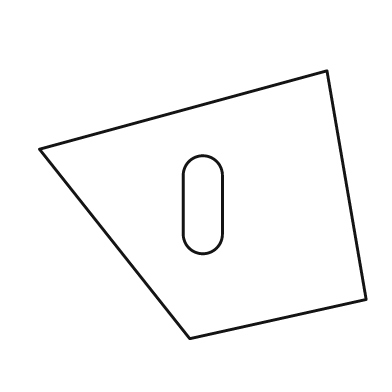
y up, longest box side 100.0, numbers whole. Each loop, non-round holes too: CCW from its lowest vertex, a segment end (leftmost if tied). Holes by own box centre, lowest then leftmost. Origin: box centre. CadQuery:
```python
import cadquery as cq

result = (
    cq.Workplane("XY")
    .moveTo(-4.0, -41.0)
    .lineTo(50.0, -29.0)
    .lineTo(38.0, 41.0)
    .lineTo(-50.0, 17.0)
    .close()
    .moveTo(-6.0, -9.0)
    .threePointArc((0.0, -15.0), (6.0, -9.0))
    .lineTo(6.0, 9.0)
    .threePointArc((0.0, 15.0), (-6.0, 9.0))
    .close()
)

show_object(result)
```